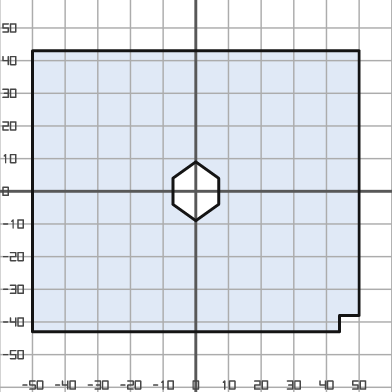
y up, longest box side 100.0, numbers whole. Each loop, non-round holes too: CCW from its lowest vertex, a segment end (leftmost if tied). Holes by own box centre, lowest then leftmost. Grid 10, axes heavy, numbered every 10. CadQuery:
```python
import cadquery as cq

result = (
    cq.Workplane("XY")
    .moveTo(-50.0, -43.0)
    .lineTo(44.0, -43.0)
    .lineTo(44.0, -38.0)
    .lineTo(50.0, -38.0)
    .lineTo(50.0, 43.0)
    .lineTo(-50.0, 43.0)
    .close()
    .moveTo(0.0, -9.0)
    .lineTo(7.0, -4.0)
    .lineTo(7.0, 4.0)
    .lineTo(0.0, 9.0)
    .lineTo(-7.0, 4.0)
    .lineTo(-7.0, -4.0)
    .close()
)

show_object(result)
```